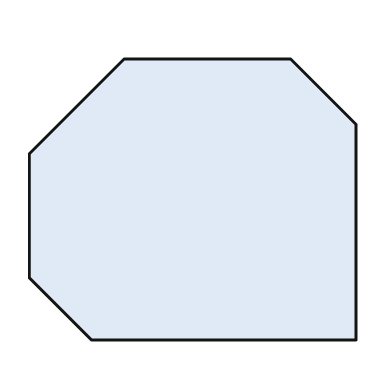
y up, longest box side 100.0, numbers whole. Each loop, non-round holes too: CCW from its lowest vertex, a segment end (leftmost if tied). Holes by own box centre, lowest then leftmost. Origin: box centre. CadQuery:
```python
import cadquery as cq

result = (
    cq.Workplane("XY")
    .moveTo(-31.0, -43.0)
    .lineTo(50.0, -43.0)
    .lineTo(50.0, 23.0)
    .lineTo(30.0, 43.0)
    .lineTo(-21.0, 43.0)
    .lineTo(-50.0, 14.0)
    .lineTo(-50.0, -24.0)
    .close()
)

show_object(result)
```